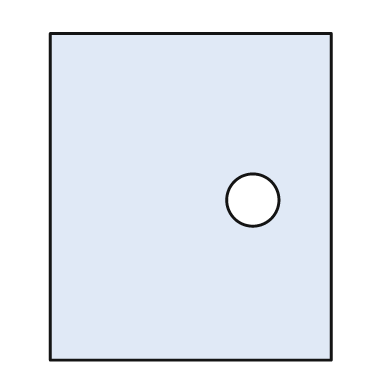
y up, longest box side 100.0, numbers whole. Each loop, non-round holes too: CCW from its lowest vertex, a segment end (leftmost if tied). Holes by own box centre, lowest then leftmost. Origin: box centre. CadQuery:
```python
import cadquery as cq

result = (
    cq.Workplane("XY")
    .moveTo(-43.0, -50.0)
    .lineTo(43.0, -50.0)
    .lineTo(43.0, 50.0)
    .lineTo(-43.0, 50.0)
    .close()
    .moveTo(19.0, -1.0)
    .circle(8.0)
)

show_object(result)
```